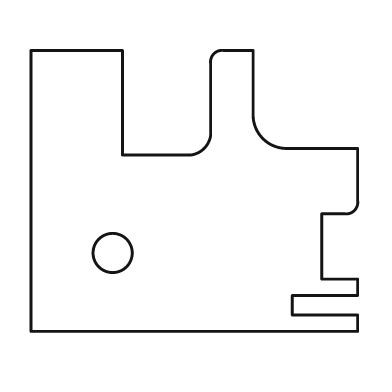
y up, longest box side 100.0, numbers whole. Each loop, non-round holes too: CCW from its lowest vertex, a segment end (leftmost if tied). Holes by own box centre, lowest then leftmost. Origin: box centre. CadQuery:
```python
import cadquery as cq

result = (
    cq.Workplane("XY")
    .moveTo(-50.0, -43.0)
    .lineTo(50.0, -43.0)
    .lineTo(50.0, -38.0)
    .lineTo(30.0, -38.0)
    .lineTo(30.0, -32.0)
    .lineTo(50.0, -32.0)
    .lineTo(50.0, -27.0)
    .lineTo(39.0, -27.0)
    .lineTo(39.0, -7.0)
    .lineTo(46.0, -7.0)
    .threePointArc((49.0, -6.0), (50.0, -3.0))
    .lineTo(50.0, 13.0)
    .lineTo(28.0, 13.0)
    .threePointArc((21.0, 16.0), (18.0, 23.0))
    .lineTo(18.0, 43.0)
    .lineTo(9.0, 43.0)
    .threePointArc((6.0, 42.0), (5.0, 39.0))
    .lineTo(5.0, 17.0)
    .threePointArc((3.0, 13.0), (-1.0, 11.0))
    .lineTo(-22.0, 11.0)
    .lineTo(-22.0, 43.0)
    .lineTo(-50.0, 43.0)
    .close()
    .moveTo(-25.0, -19.0)
    .circle(6.0)
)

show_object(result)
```